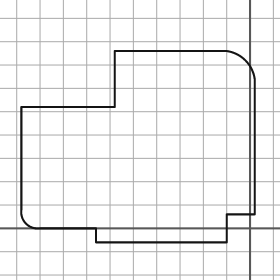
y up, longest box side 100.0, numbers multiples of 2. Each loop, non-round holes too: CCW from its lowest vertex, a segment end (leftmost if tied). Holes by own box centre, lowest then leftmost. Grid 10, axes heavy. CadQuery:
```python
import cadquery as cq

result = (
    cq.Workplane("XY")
    .moveTo(-66.0, -6.0)
    .lineTo(-10.0, -6.0)
    .lineTo(-10.0, 6.0)
    .lineTo(2.0, 6.0)
    .lineTo(2.0, 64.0)
    .threePointArc((-2.0, 72.0), (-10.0, 76.0))
    .lineTo(-58.0, 76.0)
    .lineTo(-58.0, 52.0)
    .lineTo(-98.0, 52.0)
    .lineTo(-98.0, 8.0)
    .threePointArc((-96.0, 2.0), (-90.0, 0.0))
    .lineTo(-66.0, 0.0)
    .close()
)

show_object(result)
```